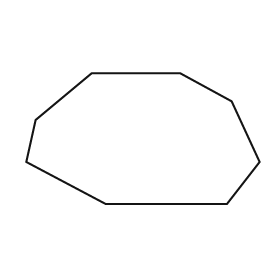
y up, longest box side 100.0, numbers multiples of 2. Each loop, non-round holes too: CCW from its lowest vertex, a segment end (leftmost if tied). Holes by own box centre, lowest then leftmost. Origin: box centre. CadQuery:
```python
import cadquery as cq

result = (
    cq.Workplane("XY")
    .moveTo(-16.0, -28.0)
    .lineTo(36.0, -28.0)
    .lineTo(50.0, -10.0)
    .lineTo(38.0, 16.0)
    .lineTo(16.0, 28.0)
    .lineTo(-22.0, 28.0)
    .lineTo(-46.0, 8.0)
    .lineTo(-50.0, -10.0)
    .close()
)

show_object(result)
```